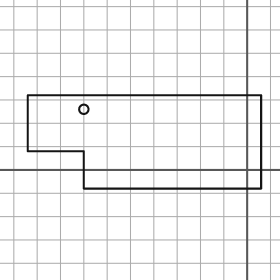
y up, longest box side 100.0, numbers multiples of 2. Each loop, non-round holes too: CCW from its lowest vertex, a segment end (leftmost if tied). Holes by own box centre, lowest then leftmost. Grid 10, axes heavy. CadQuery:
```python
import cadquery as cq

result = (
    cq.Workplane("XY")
    .moveTo(-70.0, -8.0)
    .lineTo(6.0, -8.0)
    .lineTo(6.0, 32.0)
    .lineTo(-94.0, 32.0)
    .lineTo(-94.0, 8.0)
    .lineTo(-70.0, 8.0)
    .close()
    .moveTo(-70.0, 26.0)
    .circle(2.0)
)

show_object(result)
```